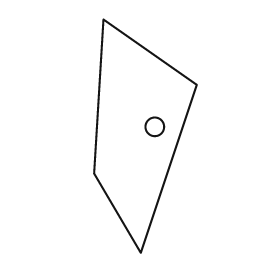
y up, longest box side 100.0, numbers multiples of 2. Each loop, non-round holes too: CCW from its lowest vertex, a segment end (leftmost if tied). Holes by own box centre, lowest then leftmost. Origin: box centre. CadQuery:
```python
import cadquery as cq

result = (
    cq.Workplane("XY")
    .moveTo(-2.0, -50.0)
    .lineTo(22.0, 22.0)
    .lineTo(-18.0, 50.0)
    .lineTo(-22.0, -16.0)
    .close()
    .moveTo(4.0, 4.0)
    .circle(4.0)
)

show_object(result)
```